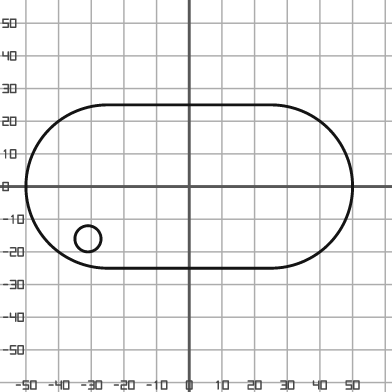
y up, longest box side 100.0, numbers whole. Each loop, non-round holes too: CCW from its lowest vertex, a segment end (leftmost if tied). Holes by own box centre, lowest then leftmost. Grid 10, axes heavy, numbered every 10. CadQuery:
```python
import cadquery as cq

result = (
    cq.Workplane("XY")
    .moveTo(-25.0, -25.0)
    .lineTo(25.0, -25.0)
    .threePointArc((50.0, 0.0), (25.0, 25.0))
    .lineTo(-25.0, 25.0)
    .threePointArc((-50.0, 0.0), (-25.0, -25.0))
    .close()
    .moveTo(-31.0, -16.0)
    .circle(4.0)
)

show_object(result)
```